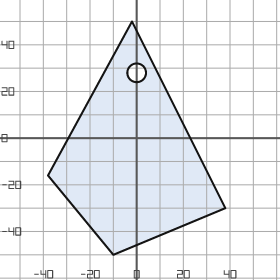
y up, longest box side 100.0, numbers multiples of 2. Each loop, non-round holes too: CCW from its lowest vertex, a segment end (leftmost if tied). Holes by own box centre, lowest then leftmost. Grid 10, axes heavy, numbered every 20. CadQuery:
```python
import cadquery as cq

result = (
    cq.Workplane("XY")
    .moveTo(-10.0, -50.0)
    .lineTo(38.0, -30.0)
    .lineTo(-2.0, 50.0)
    .lineTo(-38.0, -16.0)
    .close()
    .moveTo(0.0, 28.0)
    .circle(4.0)
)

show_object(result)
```